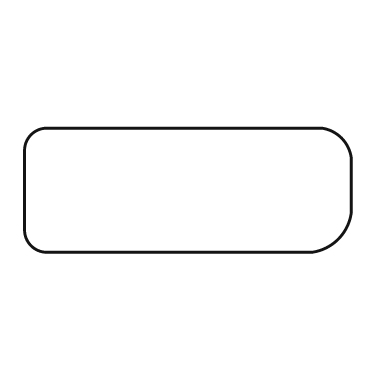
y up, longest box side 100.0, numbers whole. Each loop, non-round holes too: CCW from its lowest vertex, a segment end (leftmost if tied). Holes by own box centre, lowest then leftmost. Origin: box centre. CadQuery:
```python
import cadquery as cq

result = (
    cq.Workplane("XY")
    .moveTo(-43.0, -19.0)
    .lineTo(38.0, -19.0)
    .threePointArc((46.0, -15.0), (50.0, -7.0))
    .lineTo(50.0, 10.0)
    .threePointArc((47.0, 16.0), (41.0, 19.0))
    .lineTo(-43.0, 19.0)
    .threePointArc((-48.0, 17.0), (-50.0, 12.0))
    .lineTo(-50.0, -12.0)
    .threePointArc((-48.0, -17.0), (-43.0, -19.0))
    .close()
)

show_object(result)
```